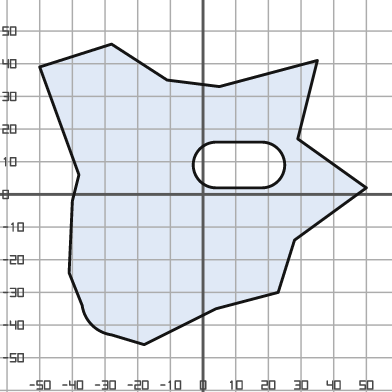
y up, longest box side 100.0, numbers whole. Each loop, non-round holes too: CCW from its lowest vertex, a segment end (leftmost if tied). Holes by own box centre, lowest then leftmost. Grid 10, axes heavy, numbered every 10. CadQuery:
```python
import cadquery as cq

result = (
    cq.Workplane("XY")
    .moveTo(-18.0, -46.0)
    .lineTo(4.0, -35.0)
    .lineTo(23.0, -30.0)
    .lineTo(28.0, -14.0)
    .lineTo(50.0, 2.0)
    .lineTo(29.0, 17.0)
    .lineTo(35.0, 41.0)
    .lineTo(5.0, 33.0)
    .lineTo(-11.0, 35.0)
    .lineTo(-28.0, 46.0)
    .lineTo(-50.0, 39.0)
    .lineTo(-38.0, 6.0)
    .lineTo(-40.0, -2.0)
    .lineTo(-41.0, -24.0)
    .lineTo(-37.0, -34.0)
    .threePointArc((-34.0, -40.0), (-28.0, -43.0))
    .close()
    .moveTo(4.0, 2.0)
    .lineTo(18.0, 2.0)
    .threePointArc((25.0, 9.0), (18.0, 16.0))
    .lineTo(4.0, 16.0)
    .threePointArc((-3.0, 9.0), (4.0, 2.0))
    .close()
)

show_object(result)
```